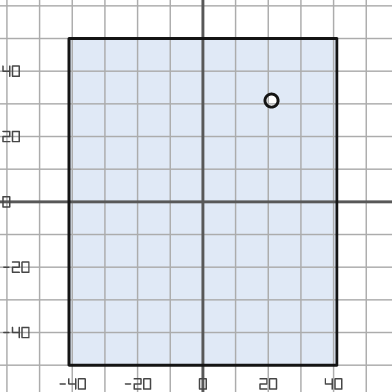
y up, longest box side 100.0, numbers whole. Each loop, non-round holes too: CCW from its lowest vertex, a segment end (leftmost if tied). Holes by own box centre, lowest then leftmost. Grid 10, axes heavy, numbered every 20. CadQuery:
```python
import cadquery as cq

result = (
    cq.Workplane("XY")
    .moveTo(-41.0, -50.0)
    .lineTo(41.0, -50.0)
    .lineTo(41.0, 50.0)
    .lineTo(-41.0, 50.0)
    .close()
    .moveTo(21.0, 31.0)
    .circle(2.0)
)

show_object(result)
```